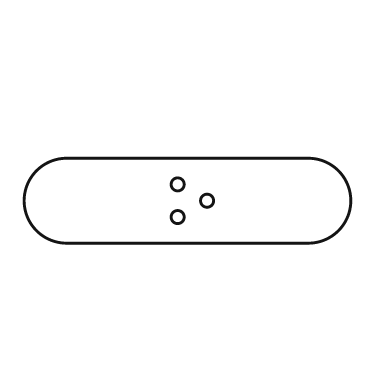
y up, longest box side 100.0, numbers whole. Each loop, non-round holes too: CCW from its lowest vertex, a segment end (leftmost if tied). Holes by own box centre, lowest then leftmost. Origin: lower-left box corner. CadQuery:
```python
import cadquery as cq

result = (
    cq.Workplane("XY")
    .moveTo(13.0, 0.0)
    .lineTo(87.0, 0.0)
    .threePointArc((100.0, 13.0), (87.0, 26.0))
    .lineTo(13.0, 26.0)
    .threePointArc((0.0, 13.0), (13.0, 0.0))
    .close()
    .moveTo(47.0, 8.0)
    .circle(2.0)
    .moveTo(56.0, 13.0)
    .circle(2.0)
    .moveTo(47.0, 18.0)
    .circle(2.0)
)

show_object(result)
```